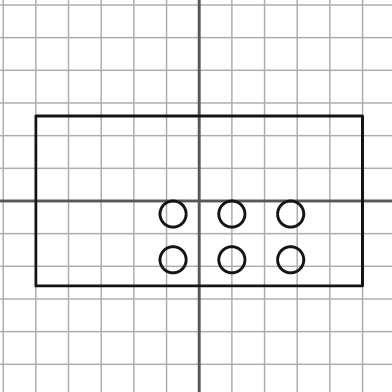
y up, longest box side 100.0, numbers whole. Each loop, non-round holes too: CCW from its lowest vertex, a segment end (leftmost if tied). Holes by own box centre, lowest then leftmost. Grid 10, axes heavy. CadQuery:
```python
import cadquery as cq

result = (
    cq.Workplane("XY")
    .moveTo(-50.0, -26.0)
    .lineTo(50.0, -26.0)
    .lineTo(50.0, 26.0)
    .lineTo(-50.0, 26.0)
    .close()
    .moveTo(-8.0, -18.0)
    .circle(4.0)
    .moveTo(10.0, -18.0)
    .circle(4.0)
    .moveTo(28.0, -18.0)
    .circle(4.0)
    .moveTo(-8.0, -4.0)
    .circle(4.0)
    .moveTo(10.0, -4.0)
    .circle(4.0)
    .moveTo(28.0, -4.0)
    .circle(4.0)
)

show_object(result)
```